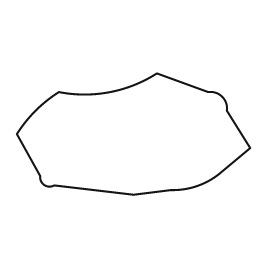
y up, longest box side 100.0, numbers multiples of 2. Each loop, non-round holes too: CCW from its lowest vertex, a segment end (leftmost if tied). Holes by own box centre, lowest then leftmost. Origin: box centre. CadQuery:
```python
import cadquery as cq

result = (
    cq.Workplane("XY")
    .moveTo(0.0, -26.0)
    .lineTo(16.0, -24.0)
    .threePointArc((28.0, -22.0), (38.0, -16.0))
    .lineTo(50.0, -6.0)
    .lineTo(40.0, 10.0)
    .threePointArc((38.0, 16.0), (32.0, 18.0))
    .lineTo(10.0, 26.0)
    .threePointArc((-10.0, 18.0), (-32.0, 18.0))
    .threePointArc((-42.0, 10.0), (-50.0, 0.0))
    .lineTo(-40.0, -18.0)
    .threePointArc((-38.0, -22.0), (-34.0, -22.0))
    .close()
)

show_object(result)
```